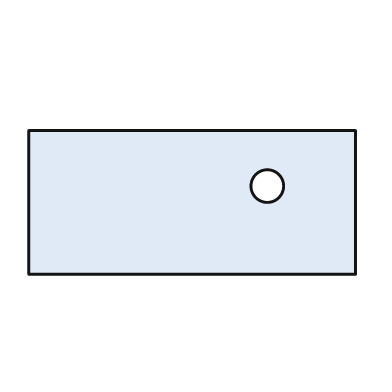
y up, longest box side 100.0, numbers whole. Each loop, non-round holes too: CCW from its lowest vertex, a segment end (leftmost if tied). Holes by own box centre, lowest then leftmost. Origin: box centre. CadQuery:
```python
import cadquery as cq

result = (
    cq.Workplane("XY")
    .moveTo(-50.0, -22.0)
    .lineTo(50.0, -22.0)
    .lineTo(50.0, 22.0)
    .lineTo(-50.0, 22.0)
    .close()
    .moveTo(23.0, 5.0)
    .circle(5.0)
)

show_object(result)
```